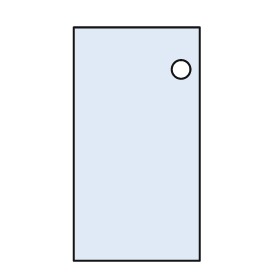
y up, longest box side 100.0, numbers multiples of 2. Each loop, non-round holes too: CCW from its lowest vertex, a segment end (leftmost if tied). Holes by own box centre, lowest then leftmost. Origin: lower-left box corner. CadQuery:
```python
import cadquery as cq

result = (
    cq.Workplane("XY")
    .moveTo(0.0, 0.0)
    .lineTo(54.0, 0.0)
    .lineTo(54.0, 100.0)
    .lineTo(0.0, 100.0)
    .close()
    .moveTo(46.0, 82.0)
    .circle(4.0)
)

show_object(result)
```